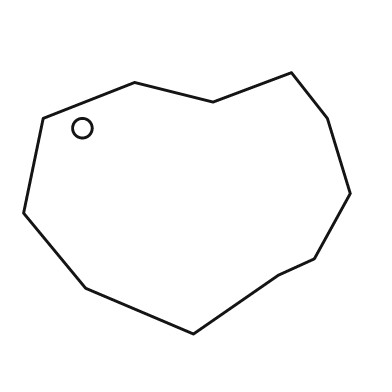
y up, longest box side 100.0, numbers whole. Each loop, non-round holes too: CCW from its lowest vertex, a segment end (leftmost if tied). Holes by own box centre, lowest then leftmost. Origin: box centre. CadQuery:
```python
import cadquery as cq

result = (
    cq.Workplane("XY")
    .moveTo(2.0, -40.0)
    .lineTo(28.0, -22.0)
    .lineTo(39.0, -17.0)
    .lineTo(50.0, 3.0)
    .lineTo(43.0, 26.0)
    .lineTo(32.0, 40.0)
    .lineTo(8.0, 31.0)
    .lineTo(-16.0, 37.0)
    .lineTo(-44.0, 26.0)
    .lineTo(-50.0, -3.0)
    .lineTo(-31.0, -26.0)
    .close()
    .moveTo(-32.0, 23.0)
    .circle(3.0)
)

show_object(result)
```